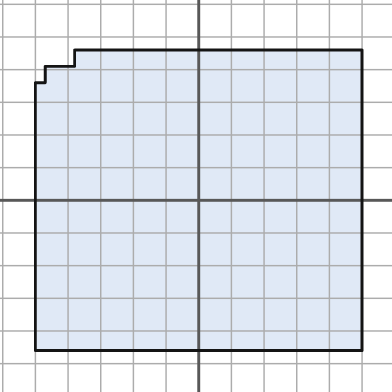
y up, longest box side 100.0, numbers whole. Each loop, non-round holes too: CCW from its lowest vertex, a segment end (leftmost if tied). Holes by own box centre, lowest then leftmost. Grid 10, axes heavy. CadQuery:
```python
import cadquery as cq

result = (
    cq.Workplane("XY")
    .moveTo(-50.0, -46.0)
    .lineTo(50.0, -46.0)
    .lineTo(50.0, 46.0)
    .lineTo(-38.0, 46.0)
    .lineTo(-38.0, 41.0)
    .lineTo(-47.0, 41.0)
    .lineTo(-47.0, 36.0)
    .lineTo(-50.0, 36.0)
    .close()
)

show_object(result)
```